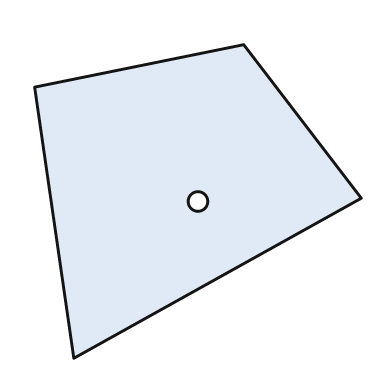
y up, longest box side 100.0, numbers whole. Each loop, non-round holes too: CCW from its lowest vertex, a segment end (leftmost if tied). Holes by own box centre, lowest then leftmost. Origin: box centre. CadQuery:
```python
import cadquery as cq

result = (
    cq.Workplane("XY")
    .moveTo(-38.0, -48.0)
    .lineTo(50.0, 1.0)
    .lineTo(14.0, 48.0)
    .lineTo(-50.0, 35.0)
    .close()
    .moveTo(0.0, 0.0)
    .circle(3.0)
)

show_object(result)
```